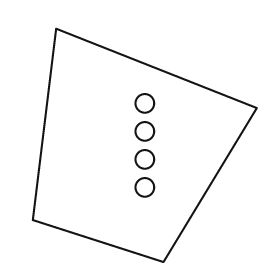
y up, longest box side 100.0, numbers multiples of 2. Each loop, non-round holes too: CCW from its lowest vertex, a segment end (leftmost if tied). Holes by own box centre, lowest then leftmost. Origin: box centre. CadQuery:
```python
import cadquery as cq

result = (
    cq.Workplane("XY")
    .moveTo(8.0, -50.0)
    .lineTo(48.0, 16.0)
    .lineTo(-38.0, 50.0)
    .lineTo(-48.0, -32.0)
    .close()
    .moveTo(0.0, -18.0)
    .circle(4.0)
    .moveTo(0.0, -6.0)
    .circle(4.0)
    .moveTo(0.0, 6.0)
    .circle(4.0)
    .moveTo(0.0, 18.0)
    .circle(4.0)
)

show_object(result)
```